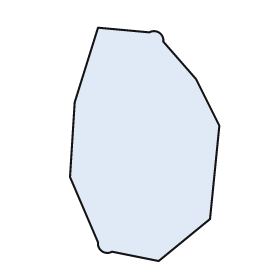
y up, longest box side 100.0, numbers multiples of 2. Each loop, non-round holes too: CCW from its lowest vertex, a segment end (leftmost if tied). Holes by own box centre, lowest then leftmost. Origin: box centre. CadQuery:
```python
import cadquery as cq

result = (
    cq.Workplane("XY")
    .moveTo(6.0, -50.0)
    .lineTo(28.0, -32.0)
    .lineTo(32.0, 8.0)
    .lineTo(22.0, 28.0)
    .lineTo(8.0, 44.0)
    .threePointArc((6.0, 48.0), (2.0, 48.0))
    .lineTo(-20.0, 50.0)
    .lineTo(-30.0, 18.0)
    .lineTo(-32.0, -14.0)
    .lineTo(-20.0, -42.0)
    .threePointArc((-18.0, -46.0), (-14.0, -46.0))
    .close()
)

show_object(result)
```